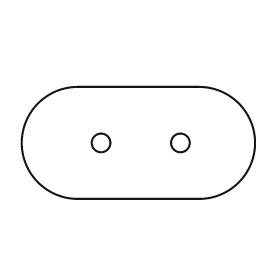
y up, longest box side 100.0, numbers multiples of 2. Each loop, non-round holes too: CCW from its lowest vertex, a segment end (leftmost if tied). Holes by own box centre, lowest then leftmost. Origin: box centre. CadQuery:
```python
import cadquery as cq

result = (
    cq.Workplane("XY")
    .moveTo(-26.0, -24.0)
    .lineTo(26.0, -24.0)
    .threePointArc((50.0, 0.0), (26.0, 24.0))
    .lineTo(-26.0, 24.0)
    .threePointArc((-50.0, 0.0), (-26.0, -24.0))
    .close()
    .moveTo(-16.0, 0.0)
    .circle(4.0)
    .moveTo(18.0, 0.0)
    .circle(4.0)
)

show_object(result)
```